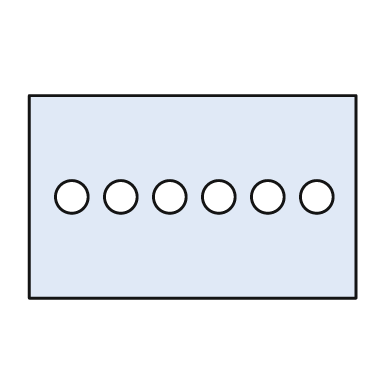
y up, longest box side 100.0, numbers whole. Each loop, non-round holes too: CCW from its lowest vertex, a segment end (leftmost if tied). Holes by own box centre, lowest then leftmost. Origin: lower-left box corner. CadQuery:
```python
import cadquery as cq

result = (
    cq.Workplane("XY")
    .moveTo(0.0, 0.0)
    .lineTo(100.0, 0.0)
    .lineTo(100.0, 62.0)
    .lineTo(0.0, 62.0)
    .close()
    .moveTo(13.0, 31.0)
    .circle(5.0)
    .moveTo(28.0, 31.0)
    .circle(5.0)
    .moveTo(43.0, 31.0)
    .circle(5.0)
    .moveTo(58.0, 31.0)
    .circle(5.0)
    .moveTo(73.0, 31.0)
    .circle(5.0)
    .moveTo(88.0, 31.0)
    .circle(5.0)
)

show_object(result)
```